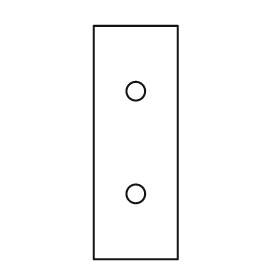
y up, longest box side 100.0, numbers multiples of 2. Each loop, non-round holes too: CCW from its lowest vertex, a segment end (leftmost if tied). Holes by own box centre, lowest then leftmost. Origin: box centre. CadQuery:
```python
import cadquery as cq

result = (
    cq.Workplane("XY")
    .moveTo(-18.0, -50.0)
    .lineTo(18.0, -50.0)
    .lineTo(18.0, 50.0)
    .lineTo(-18.0, 50.0)
    .close()
    .moveTo(0.0, -22.0)
    .circle(4.0)
    .moveTo(0.0, 22.0)
    .circle(4.0)
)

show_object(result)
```